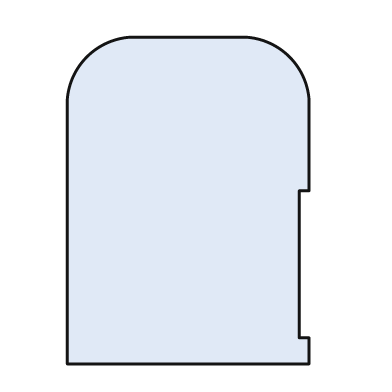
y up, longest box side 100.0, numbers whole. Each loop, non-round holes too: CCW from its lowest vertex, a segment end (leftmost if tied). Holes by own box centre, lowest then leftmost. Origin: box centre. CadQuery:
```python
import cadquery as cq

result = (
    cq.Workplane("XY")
    .moveTo(-37.0, -50.0)
    .lineTo(37.0, -50.0)
    .lineTo(37.0, -42.0)
    .lineTo(34.0, -42.0)
    .lineTo(34.0, 3.0)
    .lineTo(37.0, 3.0)
    .lineTo(37.0, 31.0)
    .threePointArc((31.0, 44.0), (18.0, 50.0))
    .lineTo(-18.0, 50.0)
    .threePointArc((-31.0, 44.0), (-37.0, 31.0))
    .close()
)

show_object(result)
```